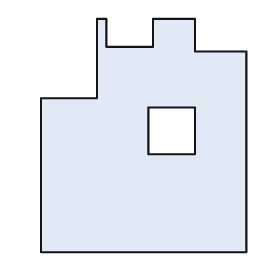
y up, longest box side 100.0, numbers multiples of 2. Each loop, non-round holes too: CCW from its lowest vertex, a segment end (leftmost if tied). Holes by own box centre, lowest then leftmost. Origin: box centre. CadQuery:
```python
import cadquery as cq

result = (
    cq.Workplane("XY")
    .moveTo(-44.0, -50.0)
    .lineTo(44.0, -50.0)
    .lineTo(44.0, 36.0)
    .lineTo(22.0, 36.0)
    .lineTo(22.0, 50.0)
    .lineTo(4.0, 50.0)
    .lineTo(4.0, 38.0)
    .lineTo(-16.0, 38.0)
    .lineTo(-16.0, 50.0)
    .lineTo(-20.0, 50.0)
    .lineTo(-20.0, 16.0)
    .lineTo(-44.0, 16.0)
    .close()
    .moveTo(2.0, -8.0)
    .lineTo(22.0, -8.0)
    .lineTo(22.0, 12.0)
    .lineTo(2.0, 12.0)
    .close()
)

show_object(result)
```